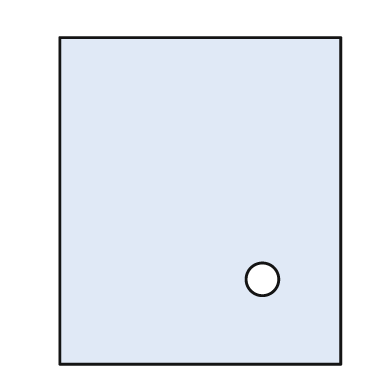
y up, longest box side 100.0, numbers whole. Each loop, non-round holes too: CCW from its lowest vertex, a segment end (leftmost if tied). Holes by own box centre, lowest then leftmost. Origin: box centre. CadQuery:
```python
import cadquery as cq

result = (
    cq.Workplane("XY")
    .moveTo(-43.0, -50.0)
    .lineTo(43.0, -50.0)
    .lineTo(43.0, 50.0)
    .lineTo(-43.0, 50.0)
    .close()
    .moveTo(19.0, -24.0)
    .circle(5.0)
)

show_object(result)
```